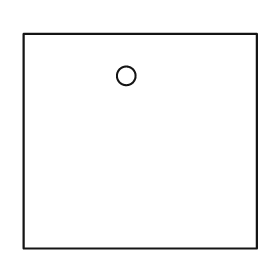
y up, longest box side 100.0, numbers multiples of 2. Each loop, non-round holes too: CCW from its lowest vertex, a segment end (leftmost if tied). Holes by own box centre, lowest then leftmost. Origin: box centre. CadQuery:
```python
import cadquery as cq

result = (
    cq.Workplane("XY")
    .moveTo(-50.0, -46.0)
    .lineTo(50.0, -46.0)
    .lineTo(50.0, 46.0)
    .lineTo(-50.0, 46.0)
    .close()
    .moveTo(-6.0, 28.0)
    .circle(4.0)
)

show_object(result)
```